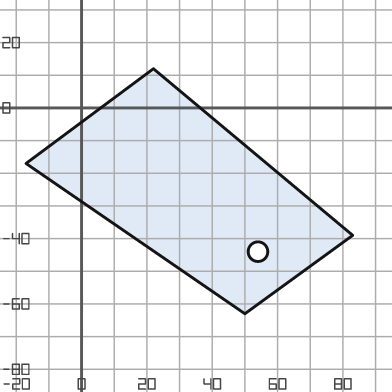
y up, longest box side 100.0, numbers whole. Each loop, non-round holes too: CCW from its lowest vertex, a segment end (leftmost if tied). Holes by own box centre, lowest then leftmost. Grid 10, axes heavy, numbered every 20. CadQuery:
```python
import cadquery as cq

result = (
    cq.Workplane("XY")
    .moveTo(50.0, -63.0)
    .lineTo(83.0, -39.0)
    .lineTo(22.0, 12.0)
    .lineTo(-17.0, -17.0)
    .close()
    .moveTo(54.0, -44.0)
    .circle(3.0)
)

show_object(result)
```